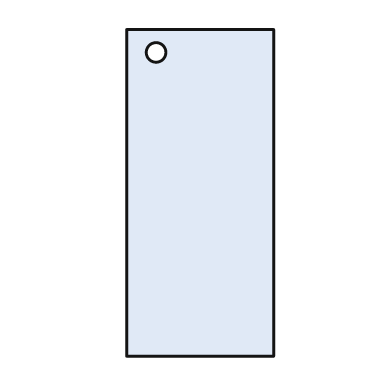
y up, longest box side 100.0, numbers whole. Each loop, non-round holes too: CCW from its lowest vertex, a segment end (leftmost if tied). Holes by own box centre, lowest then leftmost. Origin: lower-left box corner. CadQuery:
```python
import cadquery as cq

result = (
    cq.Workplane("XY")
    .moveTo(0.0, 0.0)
    .lineTo(45.0, 0.0)
    .lineTo(45.0, 100.0)
    .lineTo(0.0, 100.0)
    .close()
    .moveTo(9.0, 93.0)
    .circle(3.0)
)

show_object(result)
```